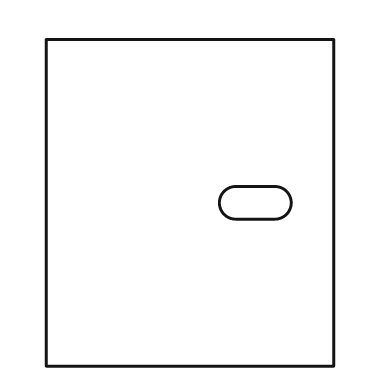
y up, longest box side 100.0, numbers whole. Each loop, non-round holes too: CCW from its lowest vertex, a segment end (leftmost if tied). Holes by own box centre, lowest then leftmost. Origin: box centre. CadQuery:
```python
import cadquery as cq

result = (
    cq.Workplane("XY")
    .moveTo(-44.0, -50.0)
    .lineTo(44.0, -50.0)
    .lineTo(44.0, 50.0)
    .lineTo(-44.0, 50.0)
    .close()
    .moveTo(14.0, -5.0)
    .lineTo(26.0, -5.0)
    .threePointArc((31.0, 0.0), (26.0, 5.0))
    .lineTo(14.0, 5.0)
    .threePointArc((9.0, 0.0), (14.0, -5.0))
    .close()
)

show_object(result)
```